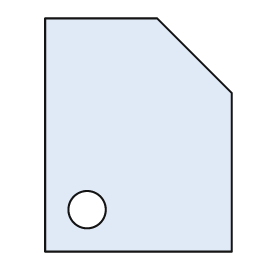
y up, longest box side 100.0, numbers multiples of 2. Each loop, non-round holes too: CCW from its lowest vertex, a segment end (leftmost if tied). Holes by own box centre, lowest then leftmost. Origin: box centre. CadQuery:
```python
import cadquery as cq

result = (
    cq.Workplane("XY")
    .moveTo(-40.0, -50.0)
    .lineTo(40.0, -50.0)
    .lineTo(40.0, 18.0)
    .lineTo(8.0, 50.0)
    .lineTo(-40.0, 50.0)
    .close()
    .moveTo(-22.0, -32.0)
    .circle(8.0)
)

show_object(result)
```